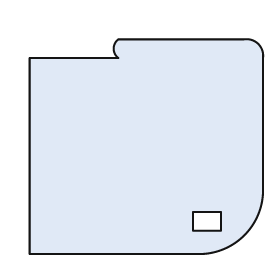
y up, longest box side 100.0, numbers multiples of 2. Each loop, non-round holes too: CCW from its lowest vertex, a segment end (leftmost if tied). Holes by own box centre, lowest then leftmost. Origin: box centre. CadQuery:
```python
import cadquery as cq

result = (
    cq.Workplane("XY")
    .moveTo(-50.0, -46.0)
    .lineTo(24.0, -46.0)
    .threePointArc((42.0, -38.0), (50.0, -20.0))
    .lineTo(50.0, 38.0)
    .threePointArc((48.0, 44.0), (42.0, 46.0))
    .lineTo(-12.0, 46.0)
    .threePointArc((-14.0, 42.0), (-12.0, 38.0))
    .lineTo(-50.0, 38.0)
    .close()
    .moveTo(20.0, -36.0)
    .lineTo(32.0, -36.0)
    .lineTo(32.0, -28.0)
    .lineTo(20.0, -28.0)
    .close()
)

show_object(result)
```